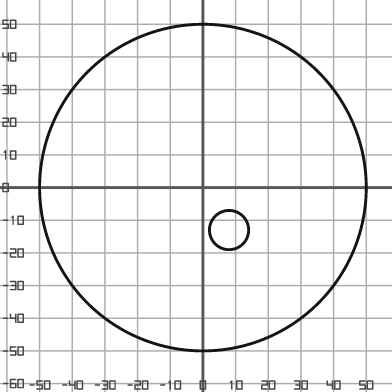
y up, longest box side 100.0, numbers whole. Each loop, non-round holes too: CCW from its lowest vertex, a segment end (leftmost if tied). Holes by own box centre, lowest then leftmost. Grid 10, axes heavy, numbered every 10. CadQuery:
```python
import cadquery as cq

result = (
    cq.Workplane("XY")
    .moveTo(0.0, 0.0)
    .circle(50.0)
    .moveTo(8.0, -13.0)
    .circle(6.0)
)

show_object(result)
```